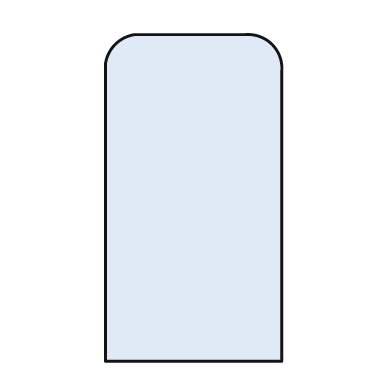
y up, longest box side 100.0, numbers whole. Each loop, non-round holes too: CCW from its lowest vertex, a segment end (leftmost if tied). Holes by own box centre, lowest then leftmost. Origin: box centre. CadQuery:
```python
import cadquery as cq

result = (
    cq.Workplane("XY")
    .moveTo(-27.0, -50.0)
    .lineTo(27.0, -50.0)
    .lineTo(27.0, 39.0)
    .threePointArc((24.0, 47.0), (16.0, 50.0))
    .lineTo(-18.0, 50.0)
    .threePointArc((-24.0, 47.0), (-27.0, 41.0))
    .close()
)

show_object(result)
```